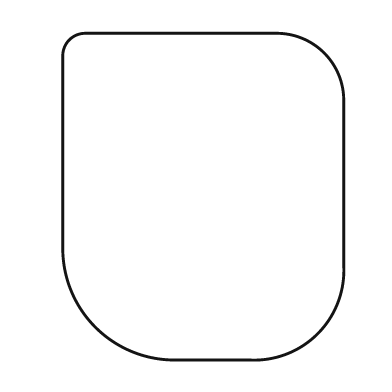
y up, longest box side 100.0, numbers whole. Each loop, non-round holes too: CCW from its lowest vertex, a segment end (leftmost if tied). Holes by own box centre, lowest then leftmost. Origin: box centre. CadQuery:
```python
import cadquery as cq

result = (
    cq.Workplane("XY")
    .moveTo(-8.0, -50.0)
    .lineTo(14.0, -50.0)
    .threePointArc((35.0, -42.0), (43.0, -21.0))
    .lineTo(43.0, 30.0)
    .threePointArc((37.0, 44.0), (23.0, 50.0))
    .lineTo(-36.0, 50.0)
    .threePointArc((-41.0, 48.0), (-43.0, 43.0))
    .lineTo(-43.0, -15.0)
    .threePointArc((-33.0, -40.0), (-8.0, -50.0))
    .close()
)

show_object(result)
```